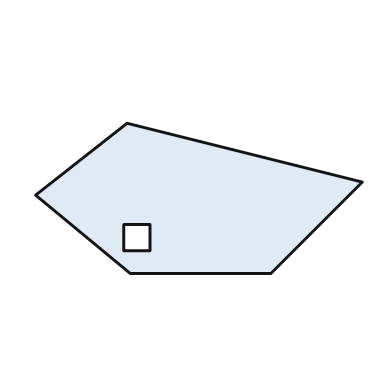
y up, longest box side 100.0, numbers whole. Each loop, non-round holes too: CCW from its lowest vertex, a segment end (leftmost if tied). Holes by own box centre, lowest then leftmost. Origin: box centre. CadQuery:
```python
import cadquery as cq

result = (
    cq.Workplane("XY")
    .moveTo(-21.0, -23.0)
    .lineTo(22.0, -23.0)
    .lineTo(50.0, 5.0)
    .lineTo(-22.0, 23.0)
    .lineTo(-50.0, 1.0)
    .close()
    .moveTo(-23.0, -16.0)
    .lineTo(-15.0, -16.0)
    .lineTo(-15.0, -8.0)
    .lineTo(-23.0, -8.0)
    .close()
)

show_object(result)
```